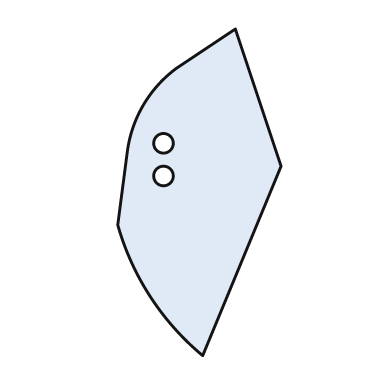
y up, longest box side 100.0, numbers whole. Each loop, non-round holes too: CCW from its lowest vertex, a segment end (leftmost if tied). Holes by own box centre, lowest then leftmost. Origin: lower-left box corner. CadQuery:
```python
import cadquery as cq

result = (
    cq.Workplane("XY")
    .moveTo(26.0, 0.0)
    .lineTo(50.0, 58.0)
    .lineTo(36.0, 100.0)
    .lineTo(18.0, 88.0)
    .threePointArc((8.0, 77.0), (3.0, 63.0))
    .lineTo(0.0, 40.0)
    .threePointArc((10.0, 18.0), (26.0, 0.0))
    .close()
    .moveTo(14.0, 55.0)
    .circle(3.0)
    .moveTo(14.0, 65.0)
    .circle(3.0)
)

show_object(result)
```